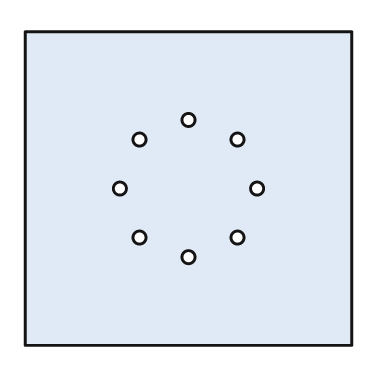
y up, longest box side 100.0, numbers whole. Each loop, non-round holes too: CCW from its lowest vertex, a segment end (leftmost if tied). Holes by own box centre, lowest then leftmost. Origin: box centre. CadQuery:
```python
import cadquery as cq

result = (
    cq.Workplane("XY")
    .moveTo(-50.0, -48.0)
    .lineTo(50.0, -48.0)
    .lineTo(50.0, 48.0)
    .lineTo(-50.0, 48.0)
    .close()
    .moveTo(0.0, -21.0)
    .circle(2.0)
    .moveTo(-15.0, -15.0)
    .circle(2.0)
    .moveTo(15.0, -15.0)
    .circle(2.0)
    .moveTo(-21.0, 0.0)
    .circle(2.0)
    .moveTo(21.0, 0.0)
    .circle(2.0)
    .moveTo(-15.0, 15.0)
    .circle(2.0)
    .moveTo(15.0, 15.0)
    .circle(2.0)
    .moveTo(0.0, 21.0)
    .circle(2.0)
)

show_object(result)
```